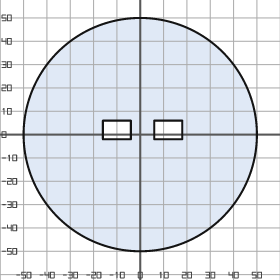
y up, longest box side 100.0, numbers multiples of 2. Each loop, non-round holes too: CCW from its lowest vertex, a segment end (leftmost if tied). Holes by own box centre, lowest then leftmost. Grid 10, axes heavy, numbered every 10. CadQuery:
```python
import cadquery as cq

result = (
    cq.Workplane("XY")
    .moveTo(0.0, 0.0)
    .circle(50.0)
    .moveTo(-16.0, -2.0)
    .lineTo(-4.0, -2.0)
    .lineTo(-4.0, 6.0)
    .lineTo(-16.0, 6.0)
    .close()
    .moveTo(6.0, -2.0)
    .lineTo(18.0, -2.0)
    .lineTo(18.0, 6.0)
    .lineTo(6.0, 6.0)
    .close()
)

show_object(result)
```